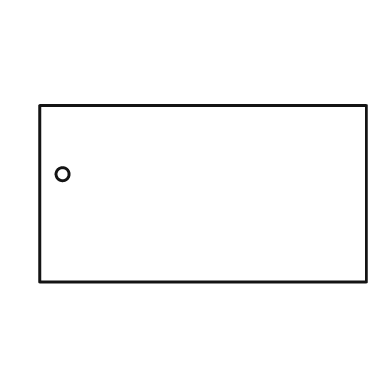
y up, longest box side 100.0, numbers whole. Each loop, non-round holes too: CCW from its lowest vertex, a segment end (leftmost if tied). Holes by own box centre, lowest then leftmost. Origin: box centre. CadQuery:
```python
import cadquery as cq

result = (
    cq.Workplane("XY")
    .moveTo(-50.0, -27.0)
    .lineTo(50.0, -27.0)
    .lineTo(50.0, 27.0)
    .lineTo(-50.0, 27.0)
    .close()
    .moveTo(-43.0, 6.0)
    .circle(2.0)
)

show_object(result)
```